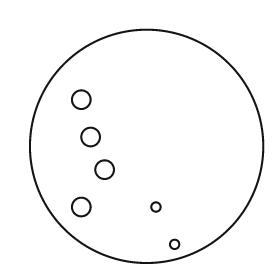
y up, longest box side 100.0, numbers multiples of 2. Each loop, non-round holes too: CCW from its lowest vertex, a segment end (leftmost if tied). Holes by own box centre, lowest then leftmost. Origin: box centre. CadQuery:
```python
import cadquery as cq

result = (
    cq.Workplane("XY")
    .moveTo(0.0, 0.0)
    .circle(50.0)
    .moveTo(12.0, -42.0)
    .circle(2.0)
    .moveTo(-28.0, -26.0)
    .circle(4.0)
    .moveTo(4.0, -26.0)
    .circle(2.0)
    .moveTo(-18.0, -10.0)
    .circle(4.0)
    .moveTo(-24.0, 4.0)
    .circle(4.0)
    .moveTo(-28.0, 20.0)
    .circle(4.0)
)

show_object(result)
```